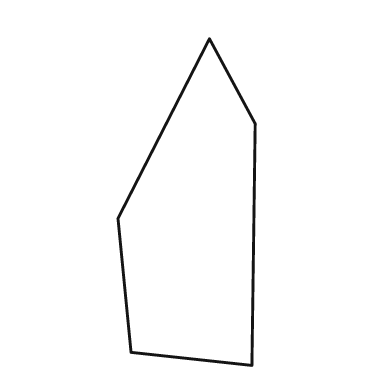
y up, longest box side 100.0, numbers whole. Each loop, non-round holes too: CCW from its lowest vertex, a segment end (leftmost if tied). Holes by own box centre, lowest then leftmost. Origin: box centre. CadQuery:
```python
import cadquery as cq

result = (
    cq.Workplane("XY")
    .moveTo(20.0, -50.0)
    .lineTo(21.0, 24.0)
    .lineTo(7.0, 50.0)
    .lineTo(-21.0, -5.0)
    .lineTo(-17.0, -46.0)
    .close()
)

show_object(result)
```